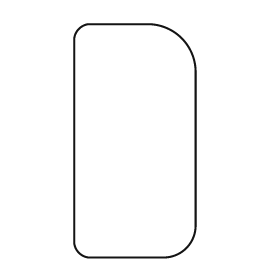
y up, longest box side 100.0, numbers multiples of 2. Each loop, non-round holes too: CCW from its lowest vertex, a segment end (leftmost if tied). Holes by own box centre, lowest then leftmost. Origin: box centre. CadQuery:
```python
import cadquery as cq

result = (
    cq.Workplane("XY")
    .moveTo(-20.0, -50.0)
    .lineTo(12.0, -50.0)
    .threePointArc((22.0, -46.0), (26.0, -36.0))
    .lineTo(26.0, 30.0)
    .threePointArc((20.0, 44.0), (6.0, 50.0))
    .lineTo(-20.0, 50.0)
    .threePointArc((-24.0, 48.0), (-26.0, 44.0))
    .lineTo(-26.0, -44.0)
    .threePointArc((-24.0, -48.0), (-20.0, -50.0))
    .close()
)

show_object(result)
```